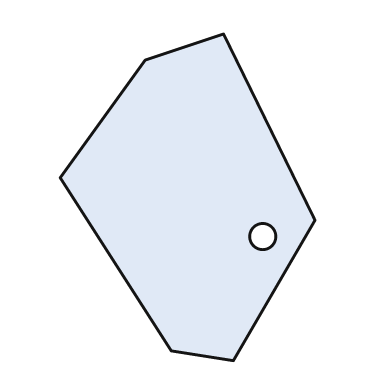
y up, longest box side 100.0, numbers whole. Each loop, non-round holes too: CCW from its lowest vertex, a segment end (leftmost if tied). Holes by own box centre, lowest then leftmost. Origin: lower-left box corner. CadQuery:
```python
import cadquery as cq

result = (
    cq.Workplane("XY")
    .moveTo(53.0, 0.0)
    .lineTo(78.0, 43.0)
    .lineTo(50.0, 100.0)
    .lineTo(26.0, 92.0)
    .lineTo(0.0, 56.0)
    .lineTo(34.0, 3.0)
    .close()
    .moveTo(62.0, 38.0)
    .circle(4.0)
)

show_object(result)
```